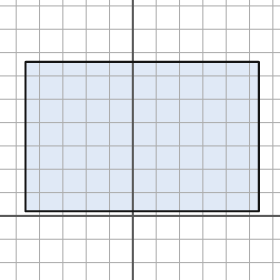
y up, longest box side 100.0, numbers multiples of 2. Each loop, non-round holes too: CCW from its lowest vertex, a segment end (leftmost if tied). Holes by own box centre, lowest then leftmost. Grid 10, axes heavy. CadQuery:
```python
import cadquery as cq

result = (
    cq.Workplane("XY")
    .moveTo(-46.0, 2.0)
    .lineTo(54.0, 2.0)
    .lineTo(54.0, 66.0)
    .lineTo(-46.0, 66.0)
    .close()
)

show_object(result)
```